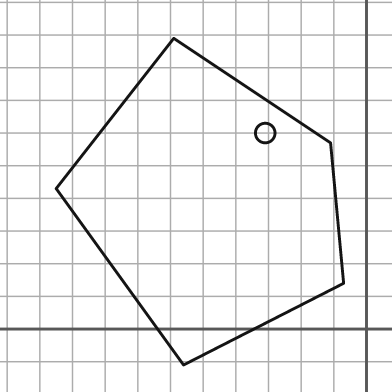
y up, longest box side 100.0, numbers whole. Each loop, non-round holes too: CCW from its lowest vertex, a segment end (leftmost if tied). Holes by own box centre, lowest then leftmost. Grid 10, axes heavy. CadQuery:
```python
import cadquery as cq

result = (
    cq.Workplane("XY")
    .moveTo(-56.0, -11.0)
    .lineTo(-7.0, 14.0)
    .lineTo(-11.0, 57.0)
    .lineTo(-59.0, 89.0)
    .lineTo(-95.0, 43.0)
    .close()
    .moveTo(-31.0, 60.0)
    .circle(3.0)
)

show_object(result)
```